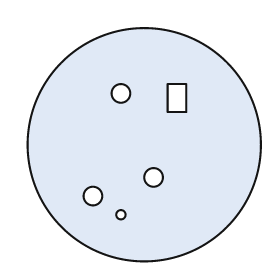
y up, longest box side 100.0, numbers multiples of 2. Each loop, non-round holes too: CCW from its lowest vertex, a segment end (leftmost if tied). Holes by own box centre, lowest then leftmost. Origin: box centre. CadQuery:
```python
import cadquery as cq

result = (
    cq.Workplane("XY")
    .moveTo(0.0, 0.0)
    .circle(50.0)
    .moveTo(-10.0, -30.0)
    .circle(2.0)
    .moveTo(-22.0, -22.0)
    .circle(4.0)
    .moveTo(4.0, -14.0)
    .circle(4.0)
    .moveTo(10.0, 14.0)
    .lineTo(18.0, 14.0)
    .lineTo(18.0, 26.0)
    .lineTo(10.0, 26.0)
    .close()
    .moveTo(-10.0, 22.0)
    .circle(4.0)
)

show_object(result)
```